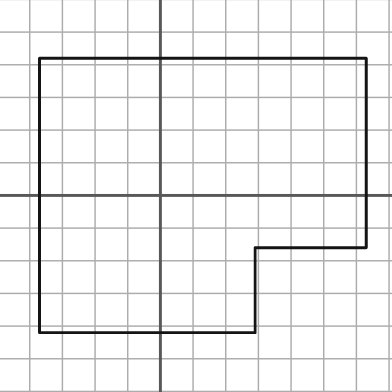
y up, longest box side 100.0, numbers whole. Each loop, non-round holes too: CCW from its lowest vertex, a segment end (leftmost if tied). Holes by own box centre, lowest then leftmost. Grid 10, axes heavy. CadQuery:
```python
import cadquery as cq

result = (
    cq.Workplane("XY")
    .moveTo(-37.0, -42.0)
    .lineTo(29.0, -42.0)
    .lineTo(29.0, -16.0)
    .lineTo(63.0, -16.0)
    .lineTo(63.0, 42.0)
    .lineTo(-37.0, 42.0)
    .close()
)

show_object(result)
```